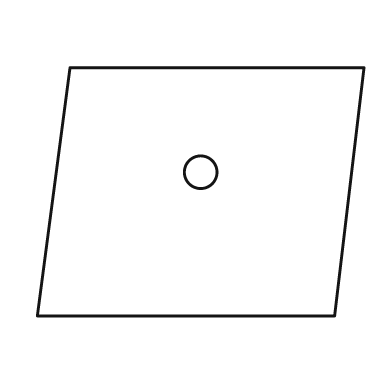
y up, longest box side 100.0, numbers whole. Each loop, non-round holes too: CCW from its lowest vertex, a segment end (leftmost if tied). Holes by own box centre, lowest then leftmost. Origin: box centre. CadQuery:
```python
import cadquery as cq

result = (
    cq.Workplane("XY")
    .moveTo(-50.0, -38.0)
    .lineTo(41.0, -38.0)
    .lineTo(50.0, 38.0)
    .lineTo(-40.0, 38.0)
    .close()
    .moveTo(0.0, 6.0)
    .circle(5.0)
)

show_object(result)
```